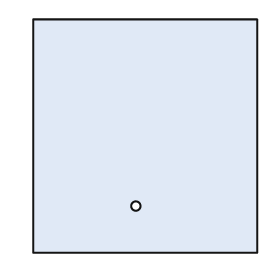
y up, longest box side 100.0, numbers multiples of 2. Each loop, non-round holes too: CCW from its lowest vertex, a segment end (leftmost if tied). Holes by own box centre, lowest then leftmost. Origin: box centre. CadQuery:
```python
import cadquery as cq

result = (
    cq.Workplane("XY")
    .moveTo(-48.0, -50.0)
    .lineTo(48.0, -50.0)
    .lineTo(48.0, 50.0)
    .lineTo(-48.0, 50.0)
    .close()
    .moveTo(-4.0, -30.0)
    .circle(2.0)
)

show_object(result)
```